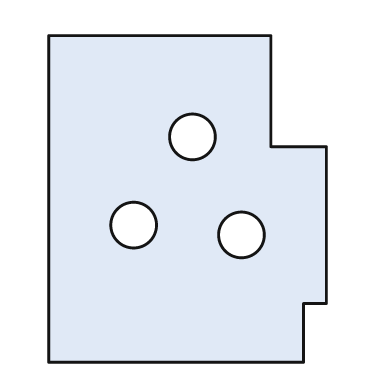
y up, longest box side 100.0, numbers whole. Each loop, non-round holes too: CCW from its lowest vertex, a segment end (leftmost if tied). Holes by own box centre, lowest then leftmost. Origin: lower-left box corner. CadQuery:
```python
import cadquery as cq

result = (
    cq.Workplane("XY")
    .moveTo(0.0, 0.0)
    .lineTo(78.0, 0.0)
    .lineTo(78.0, 18.0)
    .lineTo(85.0, 18.0)
    .lineTo(85.0, 66.0)
    .lineTo(68.0, 66.0)
    .lineTo(68.0, 100.0)
    .lineTo(0.0, 100.0)
    .close()
    .moveTo(59.0, 39.0)
    .circle(7.0)
    .moveTo(26.0, 42.0)
    .circle(7.0)
    .moveTo(44.0, 69.0)
    .circle(7.0)
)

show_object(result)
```